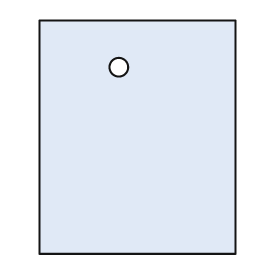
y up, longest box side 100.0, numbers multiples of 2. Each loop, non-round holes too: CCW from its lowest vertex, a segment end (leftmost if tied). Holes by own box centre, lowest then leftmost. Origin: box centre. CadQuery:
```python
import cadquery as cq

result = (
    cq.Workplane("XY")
    .moveTo(-42.0, -50.0)
    .lineTo(42.0, -50.0)
    .lineTo(42.0, 50.0)
    .lineTo(-42.0, 50.0)
    .close()
    .moveTo(-8.0, 30.0)
    .circle(4.0)
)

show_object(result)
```